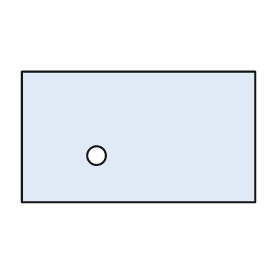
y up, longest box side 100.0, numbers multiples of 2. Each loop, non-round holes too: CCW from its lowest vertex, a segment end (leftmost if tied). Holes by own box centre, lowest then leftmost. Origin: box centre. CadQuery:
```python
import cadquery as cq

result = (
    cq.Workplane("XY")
    .moveTo(-50.0, -28.0)
    .lineTo(50.0, -28.0)
    .lineTo(50.0, 28.0)
    .lineTo(-50.0, 28.0)
    .close()
    .moveTo(-18.0, -8.0)
    .circle(4.0)
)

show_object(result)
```